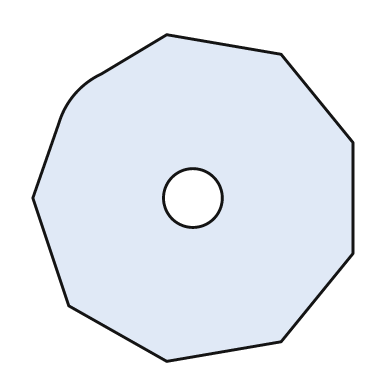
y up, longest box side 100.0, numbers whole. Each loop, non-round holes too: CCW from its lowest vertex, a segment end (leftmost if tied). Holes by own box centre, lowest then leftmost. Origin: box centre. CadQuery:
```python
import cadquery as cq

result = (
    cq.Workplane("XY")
    .moveTo(-8.0, -50.0)
    .lineTo(27.0, -44.0)
    .lineTo(49.0, -17.0)
    .lineTo(49.0, 17.0)
    .lineTo(27.0, 44.0)
    .lineTo(-8.0, 50.0)
    .lineTo(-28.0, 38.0)
    .threePointArc((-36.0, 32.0), (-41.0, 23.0))
    .lineTo(-49.0, 0.0)
    .lineTo(-38.0, -33.0)
    .close()
    .moveTo(0.0, 0.0)
    .circle(9.0)
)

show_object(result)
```